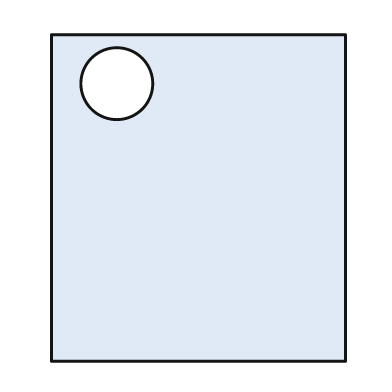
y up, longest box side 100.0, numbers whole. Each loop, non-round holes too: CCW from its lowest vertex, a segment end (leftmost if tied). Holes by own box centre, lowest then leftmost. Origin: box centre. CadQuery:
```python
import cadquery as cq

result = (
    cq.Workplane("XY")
    .moveTo(-45.0, -50.0)
    .lineTo(45.0, -50.0)
    .lineTo(45.0, 50.0)
    .lineTo(-45.0, 50.0)
    .close()
    .moveTo(-25.0, 35.0)
    .circle(11.0)
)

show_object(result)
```